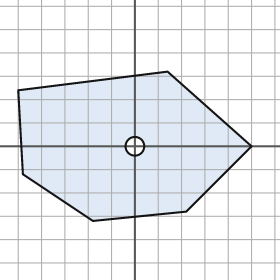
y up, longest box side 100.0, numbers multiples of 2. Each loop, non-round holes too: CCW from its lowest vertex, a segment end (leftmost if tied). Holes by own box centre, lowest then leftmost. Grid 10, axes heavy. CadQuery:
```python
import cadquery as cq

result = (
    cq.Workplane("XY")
    .moveTo(-18.0, -32.0)
    .lineTo(22.0, -28.0)
    .lineTo(50.0, 0.0)
    .lineTo(14.0, 32.0)
    .lineTo(-50.0, 24.0)
    .lineTo(-48.0, -12.0)
    .close()
    .moveTo(0.0, 0.0)
    .circle(4.0)
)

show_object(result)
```